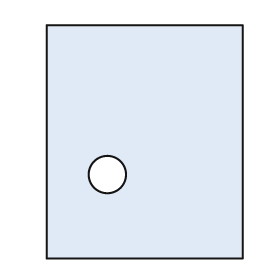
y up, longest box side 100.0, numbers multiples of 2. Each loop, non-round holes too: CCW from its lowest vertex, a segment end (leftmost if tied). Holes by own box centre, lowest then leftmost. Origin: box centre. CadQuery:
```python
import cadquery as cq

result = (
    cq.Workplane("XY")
    .moveTo(-42.0, -50.0)
    .lineTo(42.0, -50.0)
    .lineTo(42.0, 50.0)
    .lineTo(-42.0, 50.0)
    .close()
    .moveTo(-16.0, -14.0)
    .circle(8.0)
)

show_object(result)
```